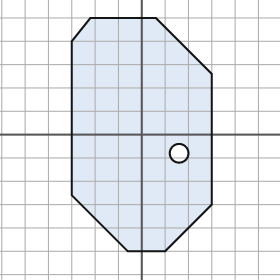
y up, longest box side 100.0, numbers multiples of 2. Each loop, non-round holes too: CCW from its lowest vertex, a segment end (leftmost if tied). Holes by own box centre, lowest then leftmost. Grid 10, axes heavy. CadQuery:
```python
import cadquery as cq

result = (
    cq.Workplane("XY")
    .moveTo(-6.0, -50.0)
    .lineTo(10.0, -50.0)
    .lineTo(30.0, -30.0)
    .lineTo(30.0, 26.0)
    .lineTo(6.0, 50.0)
    .lineTo(-22.0, 50.0)
    .lineTo(-30.0, 40.0)
    .lineTo(-30.0, -26.0)
    .close()
    .moveTo(16.0, -8.0)
    .circle(4.0)
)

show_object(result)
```